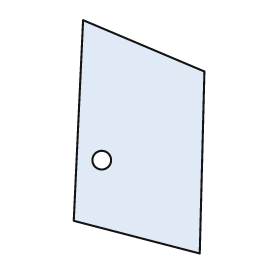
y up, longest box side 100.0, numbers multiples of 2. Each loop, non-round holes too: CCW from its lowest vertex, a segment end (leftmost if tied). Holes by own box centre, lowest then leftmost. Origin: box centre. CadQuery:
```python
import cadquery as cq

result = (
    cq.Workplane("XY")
    .moveTo(26.0, -50.0)
    .lineTo(28.0, 28.0)
    .lineTo(-24.0, 50.0)
    .lineTo(-28.0, -36.0)
    .close()
    .moveTo(-16.0, -10.0)
    .circle(4.0)
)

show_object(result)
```